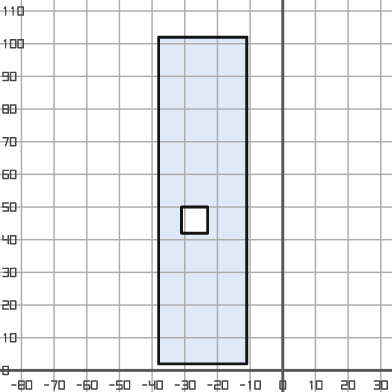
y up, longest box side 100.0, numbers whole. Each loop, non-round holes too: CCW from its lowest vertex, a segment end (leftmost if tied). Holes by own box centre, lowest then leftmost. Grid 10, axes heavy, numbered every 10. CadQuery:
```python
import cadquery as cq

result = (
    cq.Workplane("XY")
    .moveTo(-38.0, 2.0)
    .lineTo(-11.0, 2.0)
    .lineTo(-11.0, 102.0)
    .lineTo(-38.0, 102.0)
    .close()
    .moveTo(-31.0, 42.0)
    .lineTo(-23.0, 42.0)
    .lineTo(-23.0, 50.0)
    .lineTo(-31.0, 50.0)
    .close()
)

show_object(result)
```